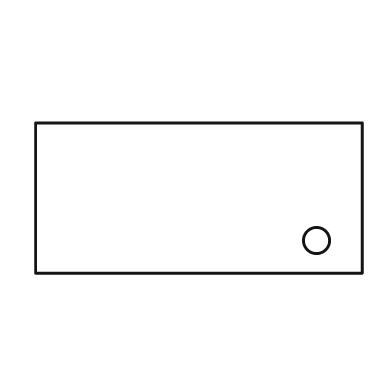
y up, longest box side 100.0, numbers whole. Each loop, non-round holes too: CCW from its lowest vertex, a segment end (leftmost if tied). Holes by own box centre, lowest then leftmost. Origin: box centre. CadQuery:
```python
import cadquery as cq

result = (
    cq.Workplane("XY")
    .moveTo(-50.0, -23.0)
    .lineTo(50.0, -23.0)
    .lineTo(50.0, 23.0)
    .lineTo(-50.0, 23.0)
    .close()
    .moveTo(36.0, -13.0)
    .circle(4.0)
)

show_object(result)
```